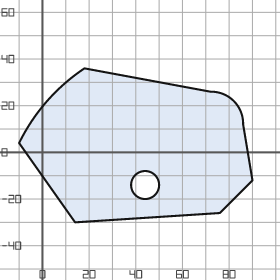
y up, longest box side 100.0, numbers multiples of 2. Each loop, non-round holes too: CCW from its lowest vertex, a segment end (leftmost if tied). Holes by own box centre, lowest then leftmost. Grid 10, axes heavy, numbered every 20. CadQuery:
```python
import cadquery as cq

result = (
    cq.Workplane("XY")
    .moveTo(14.0, -30.0)
    .lineTo(76.0, -26.0)
    .lineTo(90.0, -12.0)
    .lineTo(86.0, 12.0)
    .threePointArc((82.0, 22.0), (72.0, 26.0))
    .lineTo(18.0, 36.0)
    .threePointArc((2.0, 22.0), (-10.0, 4.0))
    .close()
    .moveTo(44.0, -14.0)
    .circle(6.0)
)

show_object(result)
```